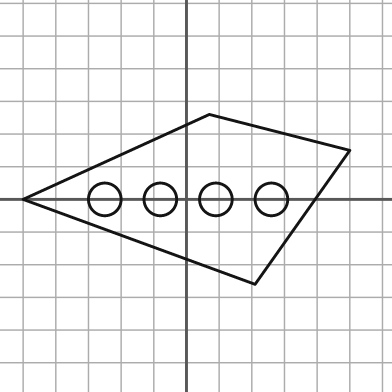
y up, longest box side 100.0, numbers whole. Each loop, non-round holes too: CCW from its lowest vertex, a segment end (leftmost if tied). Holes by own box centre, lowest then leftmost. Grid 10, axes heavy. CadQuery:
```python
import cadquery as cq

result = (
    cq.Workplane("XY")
    .moveTo(21.0, -26.0)
    .lineTo(50.0, 15.0)
    .lineTo(7.0, 26.0)
    .lineTo(-50.0, 0.0)
    .close()
    .moveTo(-25.0, 0.0)
    .circle(5.0)
    .moveTo(-8.0, 0.0)
    .circle(5.0)
    .moveTo(9.0, 0.0)
    .circle(5.0)
    .moveTo(26.0, 0.0)
    .circle(5.0)
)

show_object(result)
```